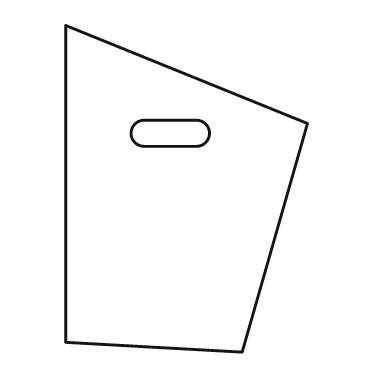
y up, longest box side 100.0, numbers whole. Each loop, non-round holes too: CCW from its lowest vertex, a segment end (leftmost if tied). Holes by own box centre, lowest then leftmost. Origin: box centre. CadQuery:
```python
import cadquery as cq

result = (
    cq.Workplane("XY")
    .moveTo(17.0, -50.0)
    .lineTo(37.0, 20.0)
    .lineTo(-37.0, 50.0)
    .lineTo(-37.0, -47.0)
    .close()
    .moveTo(-13.0, 13.0)
    .lineTo(3.0, 13.0)
    .threePointArc((7.0, 17.0), (3.0, 21.0))
    .lineTo(-13.0, 21.0)
    .threePointArc((-17.0, 17.0), (-13.0, 13.0))
    .close()
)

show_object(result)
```